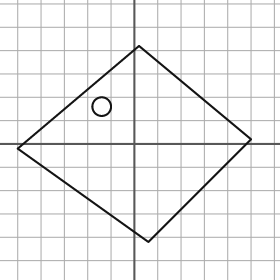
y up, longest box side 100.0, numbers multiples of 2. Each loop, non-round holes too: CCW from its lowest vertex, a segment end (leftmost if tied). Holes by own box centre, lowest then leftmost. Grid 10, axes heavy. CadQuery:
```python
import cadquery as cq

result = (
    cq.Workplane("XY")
    .moveTo(6.0, -42.0)
    .lineTo(50.0, 2.0)
    .lineTo(2.0, 42.0)
    .lineTo(-50.0, -2.0)
    .close()
    .moveTo(-14.0, 16.0)
    .circle(4.0)
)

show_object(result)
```